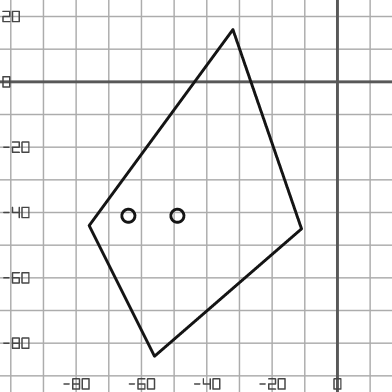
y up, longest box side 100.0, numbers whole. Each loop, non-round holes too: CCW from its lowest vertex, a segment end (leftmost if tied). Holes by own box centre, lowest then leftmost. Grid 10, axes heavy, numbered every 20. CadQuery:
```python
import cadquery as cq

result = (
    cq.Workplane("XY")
    .moveTo(-56.0, -84.0)
    .lineTo(-11.0, -45.0)
    .lineTo(-32.0, 16.0)
    .lineTo(-76.0, -44.0)
    .close()
    .moveTo(-64.0, -41.0)
    .circle(2.0)
    .moveTo(-49.0, -41.0)
    .circle(2.0)
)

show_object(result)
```